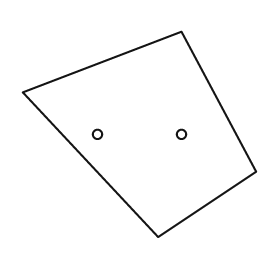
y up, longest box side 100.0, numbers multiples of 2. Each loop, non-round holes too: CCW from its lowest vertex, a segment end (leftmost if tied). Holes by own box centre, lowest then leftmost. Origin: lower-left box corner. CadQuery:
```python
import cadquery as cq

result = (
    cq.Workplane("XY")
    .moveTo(58.0, 0.0)
    .lineTo(100.0, 28.0)
    .lineTo(68.0, 88.0)
    .lineTo(0.0, 62.0)
    .close()
    .moveTo(32.0, 44.0)
    .circle(2.0)
    .moveTo(68.0, 44.0)
    .circle(2.0)
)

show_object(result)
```